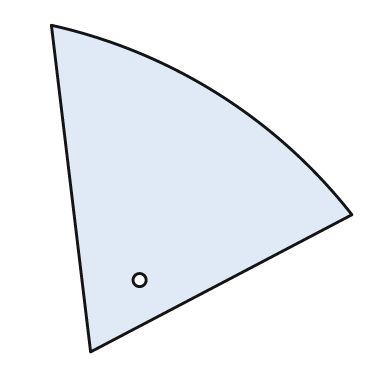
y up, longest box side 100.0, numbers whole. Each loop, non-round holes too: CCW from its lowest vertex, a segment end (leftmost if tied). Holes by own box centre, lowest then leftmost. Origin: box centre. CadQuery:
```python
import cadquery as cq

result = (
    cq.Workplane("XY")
    .moveTo(-34.0, -50.0)
    .lineTo(46.0, -8.0)
    .threePointArc((5.0, 29.0), (-46.0, 50.0))
    .close()
    .moveTo(-19.0, -28.0)
    .circle(2.0)
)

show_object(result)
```